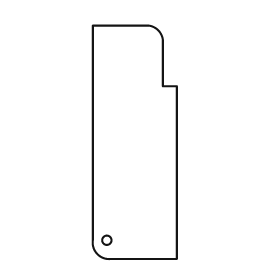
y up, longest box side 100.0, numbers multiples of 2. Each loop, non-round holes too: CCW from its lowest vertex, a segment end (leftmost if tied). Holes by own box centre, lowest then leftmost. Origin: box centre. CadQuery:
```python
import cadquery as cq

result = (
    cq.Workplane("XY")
    .moveTo(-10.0, -50.0)
    .lineTo(18.0, -50.0)
    .lineTo(18.0, 24.0)
    .lineTo(12.0, 24.0)
    .lineTo(12.0, 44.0)
    .threePointArc((10.0, 48.0), (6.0, 50.0))
    .lineTo(-18.0, 50.0)
    .lineTo(-18.0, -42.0)
    .threePointArc((-16.0, -48.0), (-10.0, -50.0))
    .close()
    .moveTo(-12.0, -42.0)
    .circle(2.0)
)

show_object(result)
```